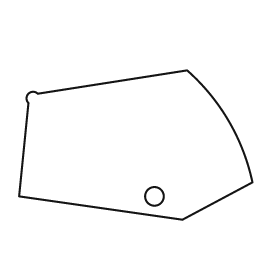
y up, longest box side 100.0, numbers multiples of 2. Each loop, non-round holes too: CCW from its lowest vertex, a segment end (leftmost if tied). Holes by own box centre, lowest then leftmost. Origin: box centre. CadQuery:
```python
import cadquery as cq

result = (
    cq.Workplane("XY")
    .moveTo(20.0, -32.0)
    .lineTo(50.0, -16.0)
    .threePointArc((40.0, 10.0), (22.0, 32.0))
    .lineTo(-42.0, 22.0)
    .threePointArc((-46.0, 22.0), (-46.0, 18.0))
    .lineTo(-50.0, -22.0)
    .close()
    .moveTo(8.0, -22.0)
    .circle(4.0)
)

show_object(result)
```